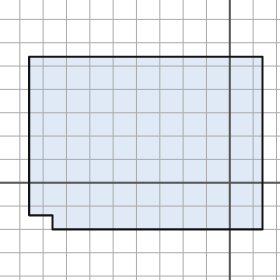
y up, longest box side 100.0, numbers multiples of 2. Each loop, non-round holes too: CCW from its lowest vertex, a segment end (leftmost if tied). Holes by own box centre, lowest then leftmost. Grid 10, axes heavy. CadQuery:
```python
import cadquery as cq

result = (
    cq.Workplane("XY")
    .moveTo(-76.0, -20.0)
    .lineTo(14.0, -20.0)
    .lineTo(14.0, 54.0)
    .lineTo(-86.0, 54.0)
    .lineTo(-86.0, -14.0)
    .lineTo(-76.0, -14.0)
    .close()
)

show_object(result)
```